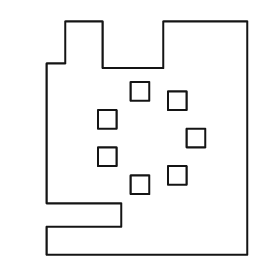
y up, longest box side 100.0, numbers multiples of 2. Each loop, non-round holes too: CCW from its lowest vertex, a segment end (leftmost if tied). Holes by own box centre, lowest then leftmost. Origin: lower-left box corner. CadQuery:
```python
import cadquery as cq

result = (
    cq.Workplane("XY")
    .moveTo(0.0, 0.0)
    .lineTo(86.0, 0.0)
    .lineTo(86.0, 100.0)
    .lineTo(50.0, 100.0)
    .lineTo(50.0, 80.0)
    .lineTo(24.0, 80.0)
    .lineTo(24.0, 100.0)
    .lineTo(8.0, 100.0)
    .lineTo(8.0, 82.0)
    .lineTo(0.0, 82.0)
    .lineTo(0.0, 22.0)
    .lineTo(32.0, 22.0)
    .lineTo(32.0, 12.0)
    .lineTo(0.0, 12.0)
    .close()
    .moveTo(36.0, 26.0)
    .lineTo(44.0, 26.0)
    .lineTo(44.0, 34.0)
    .lineTo(36.0, 34.0)
    .close()
    .moveTo(52.0, 30.0)
    .lineTo(60.0, 30.0)
    .lineTo(60.0, 38.0)
    .lineTo(52.0, 38.0)
    .close()
    .moveTo(22.0, 38.0)
    .lineTo(30.0, 38.0)
    .lineTo(30.0, 46.0)
    .lineTo(22.0, 46.0)
    .close()
    .moveTo(60.0, 46.0)
    .lineTo(68.0, 46.0)
    .lineTo(68.0, 54.0)
    .lineTo(60.0, 54.0)
    .close()
    .moveTo(22.0, 54.0)
    .lineTo(30.0, 54.0)
    .lineTo(30.0, 62.0)
    .lineTo(22.0, 62.0)
    .close()
    .moveTo(52.0, 62.0)
    .lineTo(60.0, 62.0)
    .lineTo(60.0, 70.0)
    .lineTo(52.0, 70.0)
    .close()
    .moveTo(36.0, 66.0)
    .lineTo(44.0, 66.0)
    .lineTo(44.0, 74.0)
    .lineTo(36.0, 74.0)
    .close()
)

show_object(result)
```